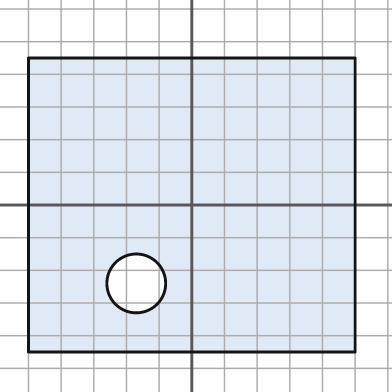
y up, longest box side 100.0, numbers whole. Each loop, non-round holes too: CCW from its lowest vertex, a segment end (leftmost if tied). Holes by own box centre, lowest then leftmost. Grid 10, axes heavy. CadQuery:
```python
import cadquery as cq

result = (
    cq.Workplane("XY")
    .moveTo(-50.0, -45.0)
    .lineTo(50.0, -45.0)
    .lineTo(50.0, 45.0)
    .lineTo(-50.0, 45.0)
    .close()
    .moveTo(-17.0, -24.0)
    .circle(9.0)
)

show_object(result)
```